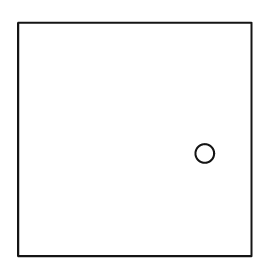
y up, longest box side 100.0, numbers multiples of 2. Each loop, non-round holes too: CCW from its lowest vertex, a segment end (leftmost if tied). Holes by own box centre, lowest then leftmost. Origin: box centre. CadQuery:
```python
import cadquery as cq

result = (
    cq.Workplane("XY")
    .moveTo(-50.0, -50.0)
    .lineTo(50.0, -50.0)
    .lineTo(50.0, 50.0)
    .lineTo(-50.0, 50.0)
    .close()
    .moveTo(30.0, -6.0)
    .circle(4.0)
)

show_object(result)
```